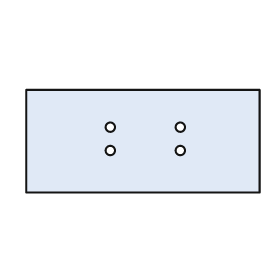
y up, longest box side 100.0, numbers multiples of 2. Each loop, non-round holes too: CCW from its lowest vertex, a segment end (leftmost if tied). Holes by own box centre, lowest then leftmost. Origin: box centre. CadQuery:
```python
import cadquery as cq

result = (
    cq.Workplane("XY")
    .moveTo(-50.0, -22.0)
    .lineTo(50.0, -22.0)
    .lineTo(50.0, 22.0)
    .lineTo(-50.0, 22.0)
    .close()
    .moveTo(-14.0, -4.0)
    .circle(2.0)
    .moveTo(16.0, -4.0)
    .circle(2.0)
    .moveTo(-14.0, 6.0)
    .circle(2.0)
    .moveTo(16.0, 6.0)
    .circle(2.0)
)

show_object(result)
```